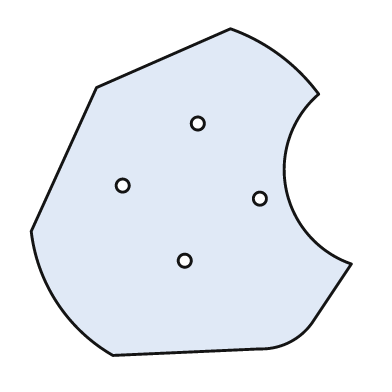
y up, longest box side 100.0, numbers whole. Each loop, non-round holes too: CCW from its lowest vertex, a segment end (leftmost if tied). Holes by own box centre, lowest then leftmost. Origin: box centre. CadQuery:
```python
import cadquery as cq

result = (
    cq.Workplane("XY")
    .moveTo(-24.0, -50.0)
    .lineTo(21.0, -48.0)
    .threePointArc((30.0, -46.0), (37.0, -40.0))
    .lineTo(49.0, -22.0)
    .threePointArc((29.0, 1.0), (39.0, 30.0))
    .threePointArc((27.0, 42.0), (12.0, 50.0))
    .lineTo(-29.0, 32.0)
    .lineTo(-49.0, -12.0)
    .threePointArc((-41.0, -34.0), (-24.0, -50.0))
    .close()
    .moveTo(-2.0, -21.0)
    .circle(2.0)
    .moveTo(21.0, -2.0)
    .circle(2.0)
    .moveTo(-21.0, 2.0)
    .circle(2.0)
    .moveTo(2.0, 21.0)
    .circle(2.0)
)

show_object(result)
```